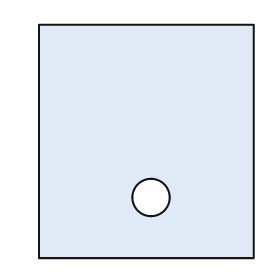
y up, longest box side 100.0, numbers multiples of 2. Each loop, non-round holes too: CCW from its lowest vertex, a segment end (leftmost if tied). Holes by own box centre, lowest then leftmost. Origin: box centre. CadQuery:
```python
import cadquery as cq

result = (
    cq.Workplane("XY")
    .moveTo(-46.0, -50.0)
    .lineTo(46.0, -50.0)
    .lineTo(46.0, 50.0)
    .lineTo(-46.0, 50.0)
    .close()
    .moveTo(2.0, -24.0)
    .circle(8.0)
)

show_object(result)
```